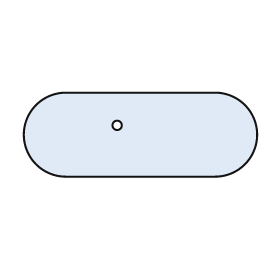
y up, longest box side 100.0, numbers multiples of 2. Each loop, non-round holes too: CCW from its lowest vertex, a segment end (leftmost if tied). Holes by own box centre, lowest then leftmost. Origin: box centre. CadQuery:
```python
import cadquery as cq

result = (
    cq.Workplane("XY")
    .moveTo(-32.0, -18.0)
    .lineTo(32.0, -18.0)
    .threePointArc((50.0, 0.0), (32.0, 18.0))
    .lineTo(-32.0, 18.0)
    .threePointArc((-50.0, 0.0), (-32.0, -18.0))
    .close()
    .moveTo(-10.0, 4.0)
    .circle(2.0)
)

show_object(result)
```